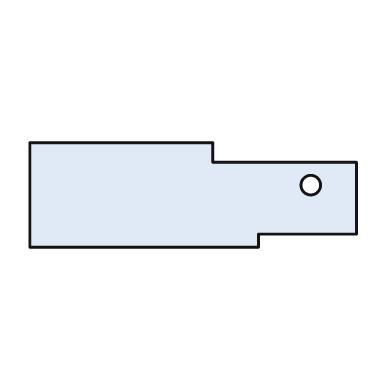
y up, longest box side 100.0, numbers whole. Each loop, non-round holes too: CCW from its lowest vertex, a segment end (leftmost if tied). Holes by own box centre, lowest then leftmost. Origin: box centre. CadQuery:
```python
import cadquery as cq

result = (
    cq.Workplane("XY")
    .moveTo(-50.0, -16.0)
    .lineTo(20.0, -16.0)
    .lineTo(20.0, -12.0)
    .lineTo(50.0, -12.0)
    .lineTo(50.0, 10.0)
    .lineTo(6.0, 10.0)
    .lineTo(6.0, 16.0)
    .lineTo(-50.0, 16.0)
    .close()
    .moveTo(36.0, 3.0)
    .circle(3.0)
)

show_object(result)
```